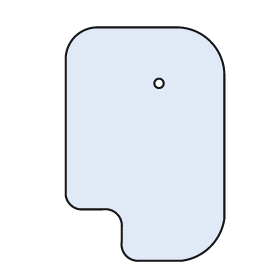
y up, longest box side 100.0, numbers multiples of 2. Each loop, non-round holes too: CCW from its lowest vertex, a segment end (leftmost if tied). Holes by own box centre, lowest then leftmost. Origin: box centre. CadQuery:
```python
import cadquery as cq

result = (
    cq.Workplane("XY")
    .moveTo(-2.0, -50.0)
    .lineTo(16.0, -50.0)
    .threePointArc((28.0, -44.0), (34.0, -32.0))
    .lineTo(34.0, 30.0)
    .threePointArc((28.0, 44.0), (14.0, 50.0))
    .lineTo(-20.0, 50.0)
    .threePointArc((-30.0, 46.0), (-34.0, 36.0))
    .lineTo(-34.0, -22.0)
    .threePointArc((-32.0, -26.0), (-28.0, -28.0))
    .lineTo(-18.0, -28.0)
    .threePointArc((-12.0, -30.0), (-10.0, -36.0))
    .lineTo(-10.0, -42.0)
    .threePointArc((-8.0, -48.0), (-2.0, -50.0))
    .close()
    .moveTo(6.0, 26.0)
    .circle(2.0)
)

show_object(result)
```